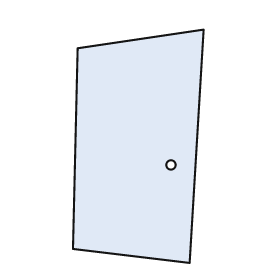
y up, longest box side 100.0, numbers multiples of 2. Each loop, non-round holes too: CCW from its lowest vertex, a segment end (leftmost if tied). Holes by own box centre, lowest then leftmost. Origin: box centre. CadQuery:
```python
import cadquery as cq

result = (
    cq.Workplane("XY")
    .moveTo(22.0, -50.0)
    .lineTo(28.0, 50.0)
    .lineTo(-26.0, 42.0)
    .lineTo(-28.0, -44.0)
    .close()
    .moveTo(14.0, -8.0)
    .circle(2.0)
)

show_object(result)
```